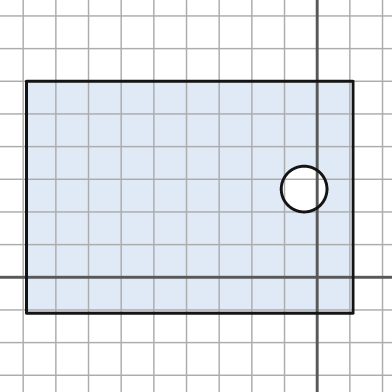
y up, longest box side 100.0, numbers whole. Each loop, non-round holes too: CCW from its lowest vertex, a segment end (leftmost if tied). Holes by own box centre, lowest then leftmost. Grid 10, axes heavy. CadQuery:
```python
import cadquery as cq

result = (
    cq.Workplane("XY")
    .moveTo(-89.0, -11.0)
    .lineTo(11.0, -11.0)
    .lineTo(11.0, 60.0)
    .lineTo(-89.0, 60.0)
    .close()
    .moveTo(-4.0, 27.0)
    .circle(7.0)
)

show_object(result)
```